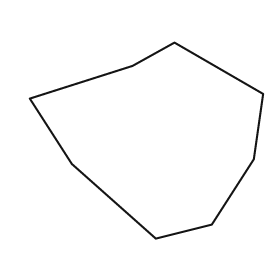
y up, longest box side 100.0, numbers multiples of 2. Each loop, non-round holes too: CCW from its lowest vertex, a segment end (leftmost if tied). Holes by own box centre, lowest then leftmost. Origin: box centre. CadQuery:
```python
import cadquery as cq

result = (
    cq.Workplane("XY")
    .moveTo(4.0, -42.0)
    .lineTo(28.0, -36.0)
    .lineTo(46.0, -8.0)
    .lineTo(50.0, 20.0)
    .lineTo(12.0, 42.0)
    .lineTo(-6.0, 32.0)
    .lineTo(-50.0, 18.0)
    .lineTo(-32.0, -10.0)
    .close()
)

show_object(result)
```